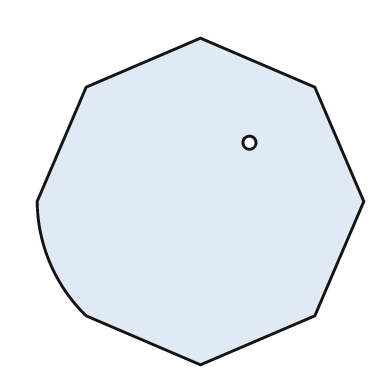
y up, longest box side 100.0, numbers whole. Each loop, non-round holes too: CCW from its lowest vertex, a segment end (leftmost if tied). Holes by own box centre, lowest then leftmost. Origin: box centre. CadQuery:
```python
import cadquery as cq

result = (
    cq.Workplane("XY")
    .moveTo(0.0, -50.0)
    .lineTo(35.0, -35.0)
    .lineTo(50.0, 0.0)
    .lineTo(35.0, 35.0)
    .lineTo(0.0, 50.0)
    .lineTo(-35.0, 35.0)
    .lineTo(-50.0, 0.0)
    .threePointArc((-46.0, -19.0), (-35.0, -35.0))
    .close()
    .moveTo(15.0, 18.0)
    .circle(2.0)
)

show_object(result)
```